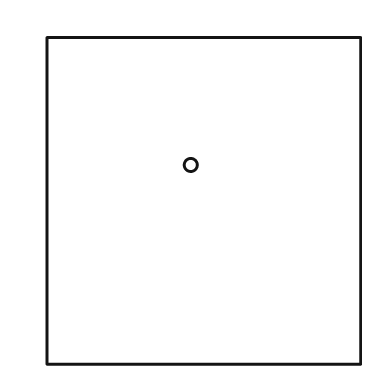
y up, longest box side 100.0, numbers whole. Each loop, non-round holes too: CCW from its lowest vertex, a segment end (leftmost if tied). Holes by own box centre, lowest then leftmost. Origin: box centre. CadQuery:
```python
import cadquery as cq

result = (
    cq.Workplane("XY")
    .moveTo(-48.0, -50.0)
    .lineTo(48.0, -50.0)
    .lineTo(48.0, 50.0)
    .lineTo(-48.0, 50.0)
    .close()
    .moveTo(-4.0, 11.0)
    .circle(2.0)
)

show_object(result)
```